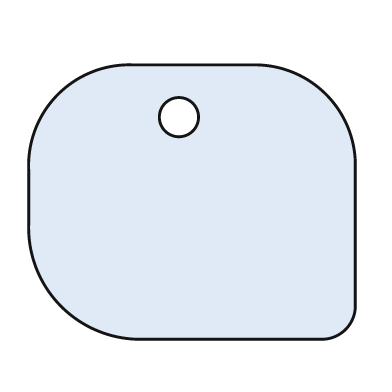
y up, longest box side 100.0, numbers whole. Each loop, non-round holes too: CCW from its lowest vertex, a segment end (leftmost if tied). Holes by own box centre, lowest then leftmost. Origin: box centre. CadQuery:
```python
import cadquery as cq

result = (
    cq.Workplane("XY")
    .moveTo(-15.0, -42.0)
    .lineTo(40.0, -42.0)
    .threePointArc((47.0, -39.0), (50.0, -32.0))
    .lineTo(50.0, 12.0)
    .threePointArc((41.0, 33.0), (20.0, 42.0))
    .lineTo(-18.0, 42.0)
    .threePointArc((-41.0, 33.0), (-50.0, 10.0))
    .lineTo(-50.0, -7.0)
    .threePointArc((-40.0, -32.0), (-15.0, -42.0))
    .close()
    .moveTo(-4.0, 26.0)
    .circle(6.0)
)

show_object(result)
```